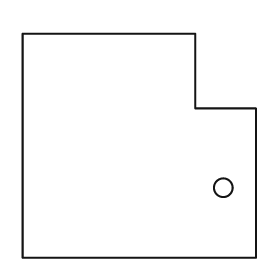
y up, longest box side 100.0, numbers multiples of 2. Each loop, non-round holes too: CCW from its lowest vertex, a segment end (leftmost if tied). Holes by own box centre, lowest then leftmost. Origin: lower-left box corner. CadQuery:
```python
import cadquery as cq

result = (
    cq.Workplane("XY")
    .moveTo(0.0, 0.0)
    .lineTo(100.0, 0.0)
    .lineTo(100.0, 64.0)
    .lineTo(74.0, 64.0)
    .lineTo(74.0, 96.0)
    .lineTo(0.0, 96.0)
    .close()
    .moveTo(86.0, 30.0)
    .circle(4.0)
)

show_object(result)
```